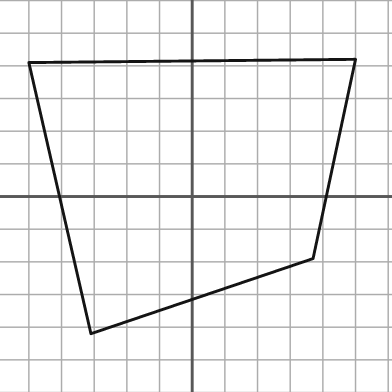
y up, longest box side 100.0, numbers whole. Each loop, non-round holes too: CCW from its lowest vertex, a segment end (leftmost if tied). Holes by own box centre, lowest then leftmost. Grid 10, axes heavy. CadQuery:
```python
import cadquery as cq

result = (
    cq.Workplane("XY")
    .moveTo(-31.0, -42.0)
    .lineTo(37.0, -19.0)
    .lineTo(50.0, 42.0)
    .lineTo(-50.0, 41.0)
    .close()
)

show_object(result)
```